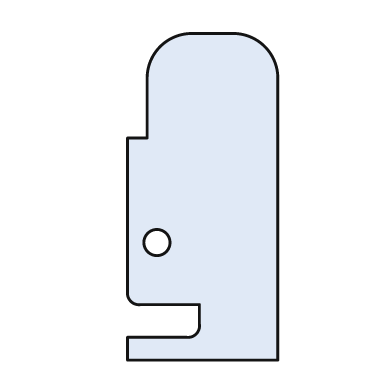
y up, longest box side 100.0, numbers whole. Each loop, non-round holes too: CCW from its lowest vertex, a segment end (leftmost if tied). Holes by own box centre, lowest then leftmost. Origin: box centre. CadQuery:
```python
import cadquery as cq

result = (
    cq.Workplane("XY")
    .moveTo(-23.0, -50.0)
    .lineTo(23.0, -50.0)
    .lineTo(23.0, 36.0)
    .threePointArc((19.0, 46.0), (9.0, 50.0))
    .lineTo(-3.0, 50.0)
    .threePointArc((-13.0, 46.0), (-17.0, 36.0))
    .lineTo(-17.0, 18.0)
    .lineTo(-23.0, 18.0)
    .lineTo(-23.0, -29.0)
    .threePointArc((-22.0, -32.0), (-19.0, -33.0))
    .lineTo(-1.0, -33.0)
    .lineTo(-1.0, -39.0)
    .threePointArc((-2.0, -42.0), (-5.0, -43.0))
    .lineTo(-23.0, -43.0)
    .close()
    .moveTo(-14.0, -14.0)
    .circle(4.0)
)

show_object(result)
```